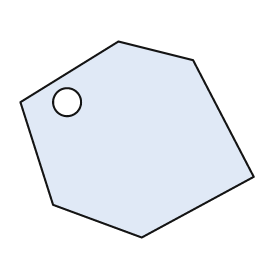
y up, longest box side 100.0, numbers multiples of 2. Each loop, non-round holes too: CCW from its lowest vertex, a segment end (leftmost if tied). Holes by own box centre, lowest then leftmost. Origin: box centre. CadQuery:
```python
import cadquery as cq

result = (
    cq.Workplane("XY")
    .moveTo(2.0, -42.0)
    .lineTo(50.0, -16.0)
    .lineTo(24.0, 34.0)
    .lineTo(-8.0, 42.0)
    .lineTo(-50.0, 16.0)
    .lineTo(-36.0, -28.0)
    .close()
    .moveTo(-30.0, 16.0)
    .circle(6.0)
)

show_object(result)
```